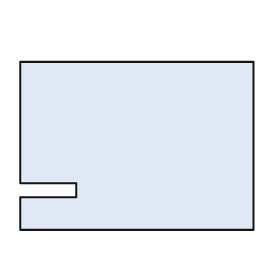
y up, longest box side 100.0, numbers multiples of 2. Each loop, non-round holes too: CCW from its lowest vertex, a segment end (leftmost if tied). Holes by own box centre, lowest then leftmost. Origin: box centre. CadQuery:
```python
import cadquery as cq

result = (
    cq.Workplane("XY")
    .moveTo(-50.0, -36.0)
    .lineTo(50.0, -36.0)
    .lineTo(50.0, 36.0)
    .lineTo(-50.0, 36.0)
    .lineTo(-50.0, -16.0)
    .lineTo(-26.0, -16.0)
    .lineTo(-26.0, -22.0)
    .lineTo(-50.0, -22.0)
    .close()
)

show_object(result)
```